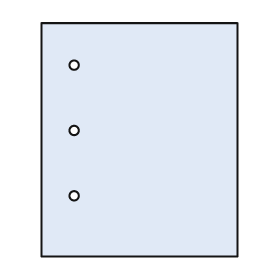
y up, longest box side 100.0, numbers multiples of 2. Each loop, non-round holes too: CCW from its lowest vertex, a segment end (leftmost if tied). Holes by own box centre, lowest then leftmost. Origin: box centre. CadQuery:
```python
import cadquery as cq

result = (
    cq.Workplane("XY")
    .moveTo(-42.0, -50.0)
    .lineTo(42.0, -50.0)
    .lineTo(42.0, 50.0)
    .lineTo(-42.0, 50.0)
    .close()
    .moveTo(-28.0, -24.0)
    .circle(2.0)
    .moveTo(-28.0, 4.0)
    .circle(2.0)
    .moveTo(-28.0, 32.0)
    .circle(2.0)
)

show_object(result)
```